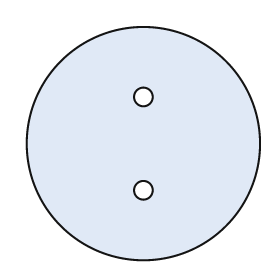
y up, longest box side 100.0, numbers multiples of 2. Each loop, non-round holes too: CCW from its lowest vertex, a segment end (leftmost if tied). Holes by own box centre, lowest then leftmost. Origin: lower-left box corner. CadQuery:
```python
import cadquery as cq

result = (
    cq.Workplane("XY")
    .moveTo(50.0, 50.0)
    .circle(50.0)
    .moveTo(50.0, 30.0)
    .circle(4.0)
    .moveTo(50.0, 70.0)
    .circle(4.0)
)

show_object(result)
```